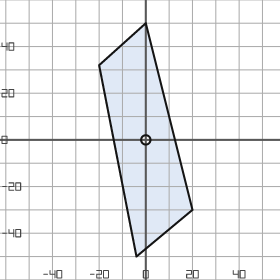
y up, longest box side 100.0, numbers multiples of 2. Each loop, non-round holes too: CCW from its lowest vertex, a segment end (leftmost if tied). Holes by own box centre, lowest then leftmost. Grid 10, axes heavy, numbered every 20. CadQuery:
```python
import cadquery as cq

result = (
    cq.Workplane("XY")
    .moveTo(-4.0, -50.0)
    .lineTo(20.0, -30.0)
    .lineTo(0.0, 50.0)
    .lineTo(-20.0, 32.0)
    .close()
    .moveTo(0.0, 0.0)
    .circle(2.0)
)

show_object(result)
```